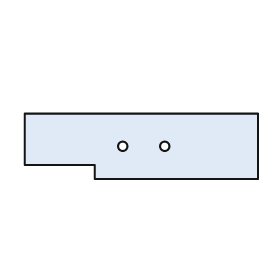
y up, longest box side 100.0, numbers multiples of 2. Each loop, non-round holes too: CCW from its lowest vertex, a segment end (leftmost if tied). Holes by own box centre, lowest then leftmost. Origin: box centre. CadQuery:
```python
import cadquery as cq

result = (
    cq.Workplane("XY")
    .moveTo(-20.0, -14.0)
    .lineTo(50.0, -14.0)
    .lineTo(50.0, 14.0)
    .lineTo(-50.0, 14.0)
    .lineTo(-50.0, -8.0)
    .lineTo(-20.0, -8.0)
    .close()
    .moveTo(-8.0, 0.0)
    .circle(2.0)
    .moveTo(10.0, 0.0)
    .circle(2.0)
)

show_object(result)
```